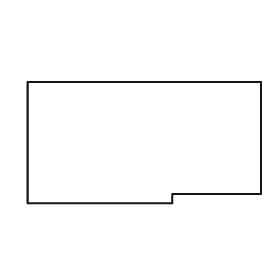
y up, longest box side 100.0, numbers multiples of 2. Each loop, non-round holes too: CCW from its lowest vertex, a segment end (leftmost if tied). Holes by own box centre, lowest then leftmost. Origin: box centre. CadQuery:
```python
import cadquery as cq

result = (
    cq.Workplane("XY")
    .moveTo(-50.0, -26.0)
    .lineTo(12.0, -26.0)
    .lineTo(12.0, -22.0)
    .lineTo(50.0, -22.0)
    .lineTo(50.0, 26.0)
    .lineTo(-50.0, 26.0)
    .close()
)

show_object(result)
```